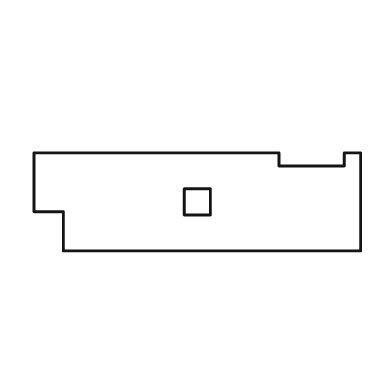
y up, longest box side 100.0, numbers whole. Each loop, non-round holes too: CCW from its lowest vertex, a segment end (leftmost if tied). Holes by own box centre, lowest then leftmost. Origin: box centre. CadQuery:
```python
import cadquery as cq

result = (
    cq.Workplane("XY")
    .moveTo(-41.0, -15.0)
    .lineTo(50.0, -15.0)
    .lineTo(50.0, 15.0)
    .lineTo(45.0, 15.0)
    .lineTo(45.0, 11.0)
    .lineTo(25.0, 11.0)
    .lineTo(25.0, 15.0)
    .lineTo(-50.0, 15.0)
    .lineTo(-50.0, -3.0)
    .lineTo(-41.0, -3.0)
    .close()
    .moveTo(-4.0, -4.0)
    .lineTo(4.0, -4.0)
    .lineTo(4.0, 4.0)
    .lineTo(-4.0, 4.0)
    .close()
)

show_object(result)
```